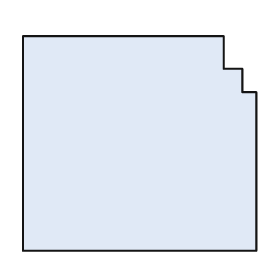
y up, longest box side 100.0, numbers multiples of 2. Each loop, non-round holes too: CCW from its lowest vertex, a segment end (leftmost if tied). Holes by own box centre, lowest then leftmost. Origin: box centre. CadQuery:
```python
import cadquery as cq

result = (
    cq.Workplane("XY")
    .moveTo(-50.0, -46.0)
    .lineTo(50.0, -46.0)
    .lineTo(50.0, 22.0)
    .lineTo(44.0, 22.0)
    .lineTo(44.0, 32.0)
    .lineTo(36.0, 32.0)
    .lineTo(36.0, 46.0)
    .lineTo(-50.0, 46.0)
    .close()
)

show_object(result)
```